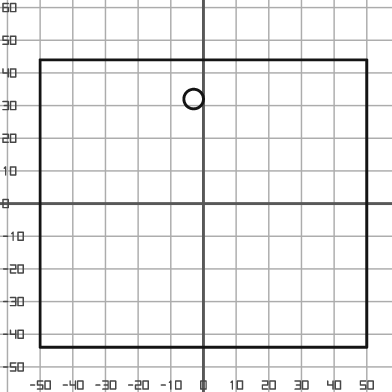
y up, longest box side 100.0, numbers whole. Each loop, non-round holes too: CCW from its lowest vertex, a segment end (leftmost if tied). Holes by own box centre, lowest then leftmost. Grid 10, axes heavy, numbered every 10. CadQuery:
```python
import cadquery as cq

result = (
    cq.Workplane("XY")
    .moveTo(-50.0, -44.0)
    .lineTo(50.0, -44.0)
    .lineTo(50.0, 44.0)
    .lineTo(-50.0, 44.0)
    .close()
    .moveTo(-3.0, 32.0)
    .circle(3.0)
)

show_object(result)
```